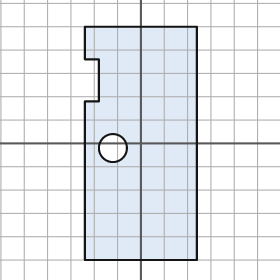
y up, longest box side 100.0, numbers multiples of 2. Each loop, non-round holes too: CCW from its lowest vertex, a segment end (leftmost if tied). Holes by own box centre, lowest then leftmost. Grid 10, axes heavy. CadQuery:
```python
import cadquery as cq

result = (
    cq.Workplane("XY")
    .moveTo(-24.0, -50.0)
    .lineTo(24.0, -50.0)
    .lineTo(24.0, 50.0)
    .lineTo(-24.0, 50.0)
    .lineTo(-24.0, 36.0)
    .lineTo(-18.0, 36.0)
    .lineTo(-18.0, 18.0)
    .lineTo(-24.0, 18.0)
    .close()
    .moveTo(-12.0, -2.0)
    .circle(6.0)
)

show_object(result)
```